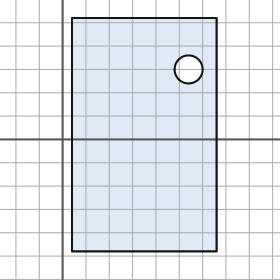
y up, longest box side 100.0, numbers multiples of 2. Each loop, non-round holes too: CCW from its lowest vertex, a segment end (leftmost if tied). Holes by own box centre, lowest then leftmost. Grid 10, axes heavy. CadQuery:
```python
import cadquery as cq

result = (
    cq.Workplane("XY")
    .moveTo(4.0, -48.0)
    .lineTo(66.0, -48.0)
    .lineTo(66.0, 52.0)
    .lineTo(4.0, 52.0)
    .close()
    .moveTo(54.0, 30.0)
    .circle(6.0)
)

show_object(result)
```